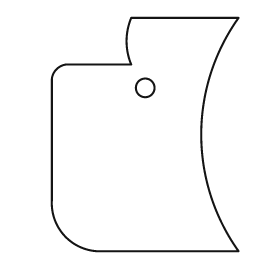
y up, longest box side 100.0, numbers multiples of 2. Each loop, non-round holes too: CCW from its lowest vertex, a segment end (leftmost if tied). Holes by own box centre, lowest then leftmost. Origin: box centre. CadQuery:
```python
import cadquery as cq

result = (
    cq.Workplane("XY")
    .moveTo(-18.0, -50.0)
    .lineTo(40.0, -50.0)
    .threePointArc((24.0, 0.0), (40.0, 50.0))
    .lineTo(-6.0, 50.0)
    .threePointArc((-8.0, 40.0), (-6.0, 30.0))
    .lineTo(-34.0, 30.0)
    .threePointArc((-38.0, 28.0), (-40.0, 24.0))
    .lineTo(-40.0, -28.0)
    .threePointArc((-34.0, -44.0), (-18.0, -50.0))
    .close()
    .moveTo(0.0, 20.0)
    .circle(4.0)
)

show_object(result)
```